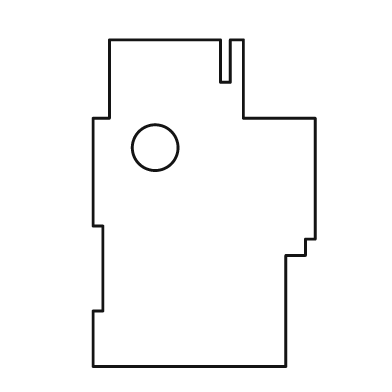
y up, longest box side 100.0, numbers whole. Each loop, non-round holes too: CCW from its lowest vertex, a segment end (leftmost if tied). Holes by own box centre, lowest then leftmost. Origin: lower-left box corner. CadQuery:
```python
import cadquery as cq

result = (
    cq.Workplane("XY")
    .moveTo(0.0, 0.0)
    .lineTo(59.0, 0.0)
    .lineTo(59.0, 34.0)
    .lineTo(65.0, 34.0)
    .lineTo(65.0, 39.0)
    .lineTo(68.0, 39.0)
    .lineTo(68.0, 76.0)
    .lineTo(46.0, 76.0)
    .lineTo(46.0, 100.0)
    .lineTo(42.0, 100.0)
    .lineTo(42.0, 87.0)
    .lineTo(39.0, 87.0)
    .lineTo(39.0, 100.0)
    .lineTo(5.0, 100.0)
    .lineTo(5.0, 76.0)
    .lineTo(0.0, 76.0)
    .lineTo(0.0, 43.0)
    .lineTo(3.0, 43.0)
    .lineTo(3.0, 17.0)
    .lineTo(0.0, 17.0)
    .close()
    .moveTo(19.0, 67.0)
    .circle(7.0)
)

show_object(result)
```